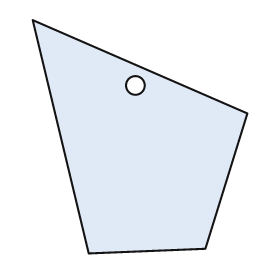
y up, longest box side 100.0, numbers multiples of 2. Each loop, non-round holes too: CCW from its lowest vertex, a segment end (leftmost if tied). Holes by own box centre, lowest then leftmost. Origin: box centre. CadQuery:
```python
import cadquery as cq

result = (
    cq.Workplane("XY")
    .moveTo(-22.0, -50.0)
    .lineTo(28.0, -48.0)
    .lineTo(46.0, 10.0)
    .lineTo(-46.0, 50.0)
    .close()
    .moveTo(-2.0, 22.0)
    .circle(4.0)
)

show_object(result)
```